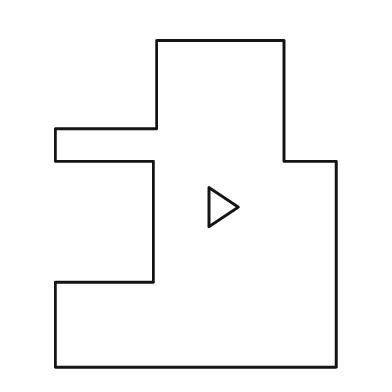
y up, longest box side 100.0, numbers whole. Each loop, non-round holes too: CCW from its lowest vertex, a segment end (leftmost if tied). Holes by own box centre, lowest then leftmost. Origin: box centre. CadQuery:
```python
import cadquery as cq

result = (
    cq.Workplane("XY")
    .moveTo(-43.0, -50.0)
    .lineTo(43.0, -50.0)
    .lineTo(43.0, 13.0)
    .lineTo(27.0, 13.0)
    .lineTo(27.0, 50.0)
    .lineTo(-12.0, 50.0)
    .lineTo(-12.0, 23.0)
    .lineTo(-43.0, 23.0)
    .lineTo(-43.0, 13.0)
    .lineTo(-13.0, 13.0)
    .lineTo(-13.0, -24.0)
    .lineTo(-43.0, -24.0)
    .close()
    .moveTo(4.0, -7.0)
    .lineTo(13.0, -1.0)
    .lineTo(4.0, 5.0)
    .close()
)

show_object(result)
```